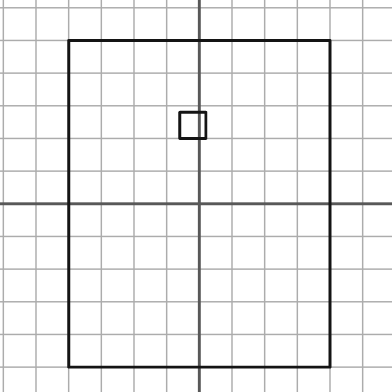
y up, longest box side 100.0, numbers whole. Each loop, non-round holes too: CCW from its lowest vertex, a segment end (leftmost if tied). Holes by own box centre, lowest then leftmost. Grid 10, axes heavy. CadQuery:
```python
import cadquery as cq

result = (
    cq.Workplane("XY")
    .moveTo(-40.0, -50.0)
    .lineTo(40.0, -50.0)
    .lineTo(40.0, 50.0)
    .lineTo(-40.0, 50.0)
    .close()
    .moveTo(-6.0, 20.0)
    .lineTo(2.0, 20.0)
    .lineTo(2.0, 28.0)
    .lineTo(-6.0, 28.0)
    .close()
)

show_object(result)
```